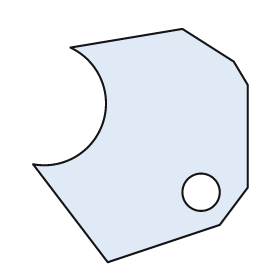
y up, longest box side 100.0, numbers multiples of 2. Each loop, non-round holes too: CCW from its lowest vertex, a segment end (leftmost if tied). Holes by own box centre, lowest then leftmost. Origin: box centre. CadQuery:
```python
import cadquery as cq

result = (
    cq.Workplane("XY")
    .moveTo(-14.0, -50.0)
    .lineTo(34.0, -34.0)
    .lineTo(46.0, -18.0)
    .lineTo(46.0, 26.0)
    .lineTo(40.0, 36.0)
    .lineTo(18.0, 50.0)
    .lineTo(-30.0, 42.0)
    .threePointArc((-16.0, 10.0), (-46.0, -8.0))
    .close()
    .moveTo(26.0, -20.0)
    .circle(8.0)
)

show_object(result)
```